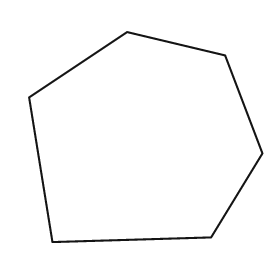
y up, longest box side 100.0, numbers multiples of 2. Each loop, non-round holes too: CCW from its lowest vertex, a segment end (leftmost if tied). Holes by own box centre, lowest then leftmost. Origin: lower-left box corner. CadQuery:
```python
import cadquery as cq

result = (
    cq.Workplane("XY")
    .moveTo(10.0, 0.0)
    .lineTo(78.0, 2.0)
    .lineTo(100.0, 38.0)
    .lineTo(84.0, 80.0)
    .lineTo(42.0, 90.0)
    .lineTo(0.0, 62.0)
    .close()
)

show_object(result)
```